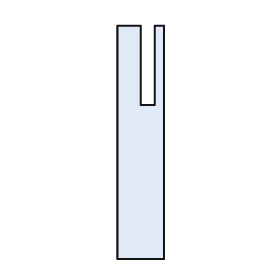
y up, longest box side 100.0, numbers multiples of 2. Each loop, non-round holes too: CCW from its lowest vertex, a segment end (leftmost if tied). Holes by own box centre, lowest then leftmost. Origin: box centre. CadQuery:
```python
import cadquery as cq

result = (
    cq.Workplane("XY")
    .moveTo(-10.0, -50.0)
    .lineTo(10.0, -50.0)
    .lineTo(10.0, 50.0)
    .lineTo(6.0, 50.0)
    .lineTo(6.0, 16.0)
    .lineTo(0.0, 16.0)
    .lineTo(0.0, 50.0)
    .lineTo(-10.0, 50.0)
    .close()
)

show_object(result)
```